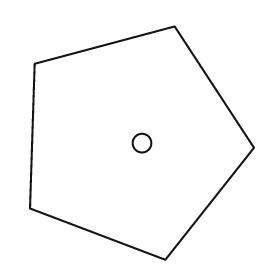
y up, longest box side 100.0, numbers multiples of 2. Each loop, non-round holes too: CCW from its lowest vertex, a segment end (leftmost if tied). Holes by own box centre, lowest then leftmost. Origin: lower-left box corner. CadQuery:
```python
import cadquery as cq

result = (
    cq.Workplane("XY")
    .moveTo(58.0, 0.0)
    .lineTo(96.0, 48.0)
    .lineTo(62.0, 100.0)
    .lineTo(2.0, 84.0)
    .lineTo(0.0, 22.0)
    .close()
    .moveTo(48.0, 50.0)
    .circle(4.0)
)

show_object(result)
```